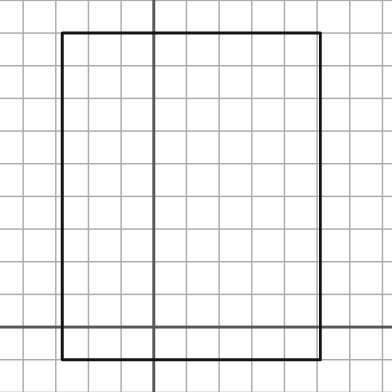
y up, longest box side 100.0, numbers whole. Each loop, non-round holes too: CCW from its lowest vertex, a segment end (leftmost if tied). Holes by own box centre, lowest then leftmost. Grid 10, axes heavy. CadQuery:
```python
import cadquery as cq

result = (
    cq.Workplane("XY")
    .moveTo(-28.0, -10.0)
    .lineTo(51.0, -10.0)
    .lineTo(51.0, 90.0)
    .lineTo(-28.0, 90.0)
    .close()
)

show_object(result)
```